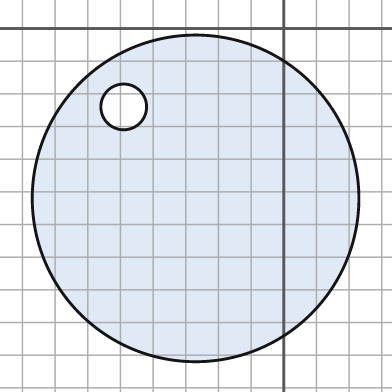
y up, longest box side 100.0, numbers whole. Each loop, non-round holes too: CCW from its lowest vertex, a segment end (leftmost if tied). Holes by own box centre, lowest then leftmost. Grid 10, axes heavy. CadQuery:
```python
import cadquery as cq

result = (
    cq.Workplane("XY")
    .moveTo(-27.0, -52.0)
    .circle(50.0)
    .moveTo(-49.0, -24.0)
    .circle(7.0)
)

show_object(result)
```